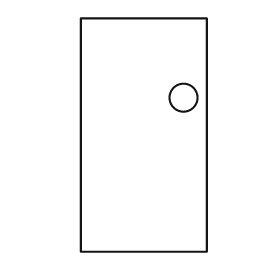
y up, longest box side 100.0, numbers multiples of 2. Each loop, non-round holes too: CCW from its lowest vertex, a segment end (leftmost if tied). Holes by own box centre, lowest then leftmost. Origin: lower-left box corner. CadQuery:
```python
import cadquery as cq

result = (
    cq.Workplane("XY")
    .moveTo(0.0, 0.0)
    .lineTo(54.0, 0.0)
    .lineTo(54.0, 100.0)
    .lineTo(0.0, 100.0)
    .close()
    .moveTo(44.0, 66.0)
    .circle(6.0)
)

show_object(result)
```